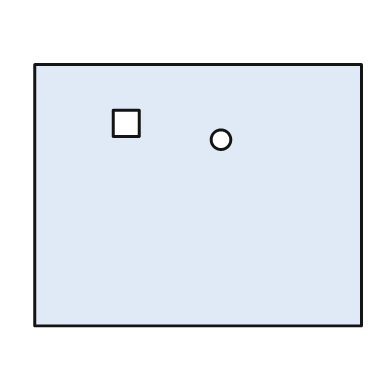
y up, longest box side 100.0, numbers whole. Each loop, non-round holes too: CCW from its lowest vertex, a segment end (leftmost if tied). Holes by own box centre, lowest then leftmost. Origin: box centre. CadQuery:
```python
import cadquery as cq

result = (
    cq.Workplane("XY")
    .moveTo(-50.0, -40.0)
    .lineTo(50.0, -40.0)
    .lineTo(50.0, 40.0)
    .lineTo(-50.0, 40.0)
    .close()
    .moveTo(7.0, 17.0)
    .circle(3.0)
    .moveTo(-26.0, 18.0)
    .lineTo(-18.0, 18.0)
    .lineTo(-18.0, 26.0)
    .lineTo(-26.0, 26.0)
    .close()
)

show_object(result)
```